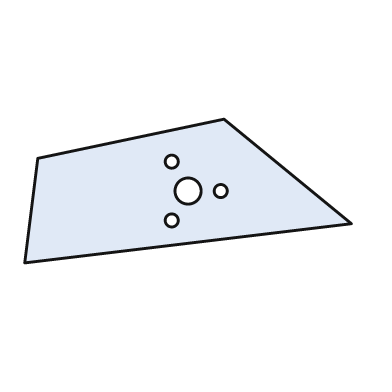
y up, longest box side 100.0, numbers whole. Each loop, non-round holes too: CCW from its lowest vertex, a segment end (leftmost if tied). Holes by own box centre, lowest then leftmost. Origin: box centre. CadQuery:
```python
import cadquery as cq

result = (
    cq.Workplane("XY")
    .moveTo(-50.0, -22.0)
    .lineTo(50.0, -10.0)
    .lineTo(11.0, 22.0)
    .lineTo(-46.0, 10.0)
    .close()
    .moveTo(-5.0, -9.0)
    .circle(2.0)
    .moveTo(0.0, 0.0)
    .circle(4.0)
    .moveTo(10.0, 0.0)
    .circle(2.0)
    .moveTo(-5.0, 9.0)
    .circle(2.0)
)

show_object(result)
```